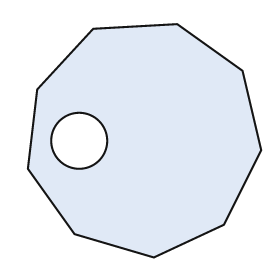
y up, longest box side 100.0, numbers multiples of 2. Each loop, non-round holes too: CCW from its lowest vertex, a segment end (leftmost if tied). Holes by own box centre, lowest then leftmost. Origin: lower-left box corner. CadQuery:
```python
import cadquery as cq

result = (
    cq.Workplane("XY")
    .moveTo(54.0, 0.0)
    .lineTo(84.0, 14.0)
    .lineTo(100.0, 46.0)
    .lineTo(92.0, 80.0)
    .lineTo(64.0, 100.0)
    .lineTo(28.0, 98.0)
    .lineTo(4.0, 72.0)
    .lineTo(0.0, 38.0)
    .lineTo(20.0, 10.0)
    .close()
    .moveTo(22.0, 50.0)
    .circle(12.0)
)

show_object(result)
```